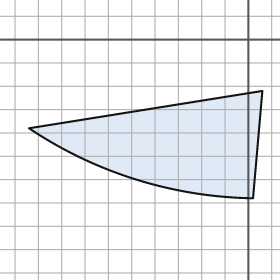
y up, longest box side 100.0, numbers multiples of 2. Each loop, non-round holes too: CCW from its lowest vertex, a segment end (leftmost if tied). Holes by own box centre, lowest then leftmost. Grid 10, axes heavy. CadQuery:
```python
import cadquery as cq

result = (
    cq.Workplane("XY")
    .moveTo(2.0, -68.0)
    .lineTo(6.0, -22.0)
    .lineTo(-94.0, -38.0)
    .threePointArc((-48.0, -60.0), (2.0, -68.0))
    .close()
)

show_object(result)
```